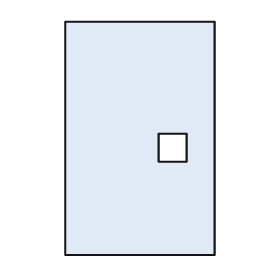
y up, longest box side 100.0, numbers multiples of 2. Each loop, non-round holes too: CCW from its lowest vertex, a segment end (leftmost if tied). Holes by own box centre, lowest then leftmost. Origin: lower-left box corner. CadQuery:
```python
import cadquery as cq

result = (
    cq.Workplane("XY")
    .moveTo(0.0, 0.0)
    .lineTo(64.0, 0.0)
    .lineTo(64.0, 100.0)
    .lineTo(0.0, 100.0)
    .close()
    .moveTo(40.0, 40.0)
    .lineTo(52.0, 40.0)
    .lineTo(52.0, 52.0)
    .lineTo(40.0, 52.0)
    .close()
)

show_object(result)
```